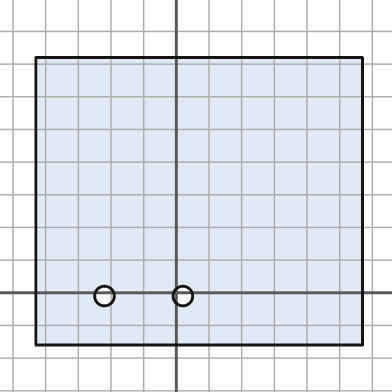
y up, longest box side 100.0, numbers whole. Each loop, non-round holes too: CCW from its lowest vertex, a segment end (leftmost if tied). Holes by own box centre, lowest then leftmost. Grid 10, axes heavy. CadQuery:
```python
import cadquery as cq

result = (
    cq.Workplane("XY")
    .moveTo(-43.0, -16.0)
    .lineTo(57.0, -16.0)
    .lineTo(57.0, 72.0)
    .lineTo(-43.0, 72.0)
    .close()
    .moveTo(-22.0, -1.0)
    .circle(3.0)
    .moveTo(2.0, -1.0)
    .circle(3.0)
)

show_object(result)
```